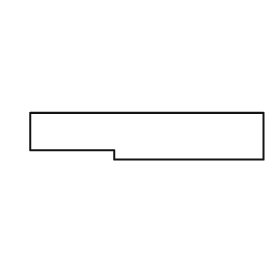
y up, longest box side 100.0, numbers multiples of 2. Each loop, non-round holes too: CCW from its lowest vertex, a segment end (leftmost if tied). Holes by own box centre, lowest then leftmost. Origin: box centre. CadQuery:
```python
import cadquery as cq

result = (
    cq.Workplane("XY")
    .moveTo(-14.0, -10.0)
    .lineTo(50.0, -10.0)
    .lineTo(50.0, 10.0)
    .lineTo(-50.0, 10.0)
    .lineTo(-50.0, -6.0)
    .lineTo(-14.0, -6.0)
    .close()
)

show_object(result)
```